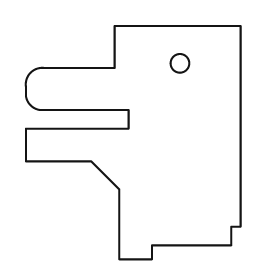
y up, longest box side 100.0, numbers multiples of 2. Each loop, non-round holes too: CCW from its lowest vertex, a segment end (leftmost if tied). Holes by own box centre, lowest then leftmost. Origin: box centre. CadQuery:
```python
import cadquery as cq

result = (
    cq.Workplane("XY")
    .moveTo(-6.0, -50.0)
    .lineTo(8.0, -50.0)
    .lineTo(8.0, -44.0)
    .lineTo(42.0, -44.0)
    .lineTo(42.0, -36.0)
    .lineTo(46.0, -36.0)
    .lineTo(46.0, 50.0)
    .lineTo(-8.0, 50.0)
    .lineTo(-8.0, 32.0)
    .lineTo(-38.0, 32.0)
    .threePointArc((-44.0, 30.0), (-46.0, 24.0))
    .lineTo(-46.0, 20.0)
    .threePointArc((-44.0, 16.0), (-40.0, 14.0))
    .lineTo(-2.0, 14.0)
    .lineTo(-2.0, 6.0)
    .lineTo(-46.0, 6.0)
    .lineTo(-46.0, -8.0)
    .lineTo(-18.0, -8.0)
    .lineTo(-6.0, -20.0)
    .close()
    .moveTo(20.0, 34.0)
    .circle(4.0)
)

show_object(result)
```